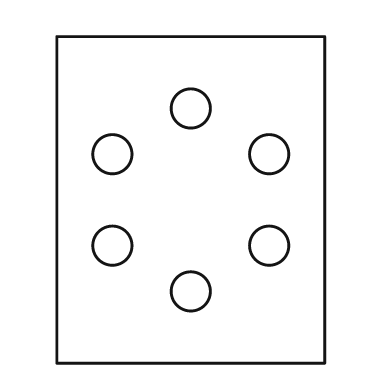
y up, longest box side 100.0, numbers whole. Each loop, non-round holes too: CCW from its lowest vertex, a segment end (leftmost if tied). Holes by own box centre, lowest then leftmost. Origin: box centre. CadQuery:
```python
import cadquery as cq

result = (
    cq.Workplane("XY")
    .moveTo(-41.0, -50.0)
    .lineTo(41.0, -50.0)
    .lineTo(41.0, 50.0)
    .lineTo(-41.0, 50.0)
    .close()
    .moveTo(0.0, -28.0)
    .circle(6.0)
    .moveTo(-24.0, -14.0)
    .circle(6.0)
    .moveTo(24.0, -14.0)
    .circle(6.0)
    .moveTo(-24.0, 14.0)
    .circle(6.0)
    .moveTo(24.0, 14.0)
    .circle(6.0)
    .moveTo(0.0, 28.0)
    .circle(6.0)
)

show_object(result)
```